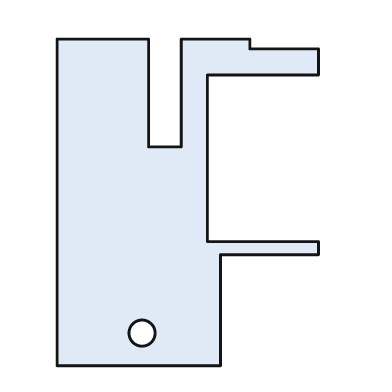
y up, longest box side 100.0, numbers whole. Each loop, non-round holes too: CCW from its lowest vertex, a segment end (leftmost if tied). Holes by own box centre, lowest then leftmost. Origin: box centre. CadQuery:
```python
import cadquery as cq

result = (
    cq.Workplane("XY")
    .moveTo(-40.0, -50.0)
    .lineTo(10.0, -50.0)
    .lineTo(10.0, -16.0)
    .lineTo(40.0, -16.0)
    .lineTo(40.0, -12.0)
    .lineTo(6.0, -12.0)
    .lineTo(6.0, 39.0)
    .lineTo(40.0, 39.0)
    .lineTo(40.0, 47.0)
    .lineTo(19.0, 47.0)
    .lineTo(19.0, 50.0)
    .lineTo(-2.0, 50.0)
    .lineTo(-2.0, 17.0)
    .lineTo(-12.0, 17.0)
    .lineTo(-12.0, 50.0)
    .lineTo(-40.0, 50.0)
    .close()
    .moveTo(-14.0, -40.0)
    .circle(4.0)
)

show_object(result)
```